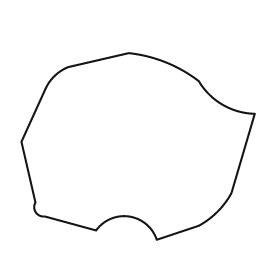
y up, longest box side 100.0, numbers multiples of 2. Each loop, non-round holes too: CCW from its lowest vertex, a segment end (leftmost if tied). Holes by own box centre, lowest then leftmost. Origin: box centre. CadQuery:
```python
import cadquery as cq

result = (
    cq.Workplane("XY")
    .moveTo(8.0, -40.0)
    .lineTo(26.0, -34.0)
    .threePointArc((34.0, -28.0), (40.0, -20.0))
    .lineTo(50.0, 14.0)
    .threePointArc((36.0, 18.0), (26.0, 28.0))
    .threePointArc((12.0, 36.0), (-4.0, 40.0))
    .lineTo(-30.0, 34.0)
    .threePointArc((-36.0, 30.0), (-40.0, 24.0))
    .lineTo(-50.0, 2.0)
    .lineTo(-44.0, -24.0)
    .threePointArc((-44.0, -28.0), (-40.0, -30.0))
    .lineTo(-18.0, -36.0)
    .threePointArc((-4.0, -30.0), (8.0, -40.0))
    .close()
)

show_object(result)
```